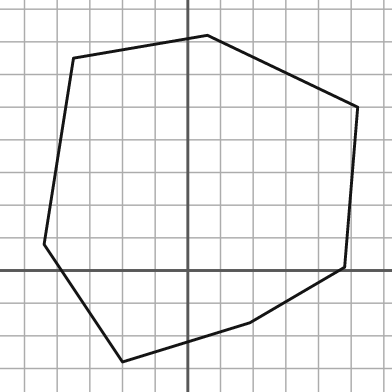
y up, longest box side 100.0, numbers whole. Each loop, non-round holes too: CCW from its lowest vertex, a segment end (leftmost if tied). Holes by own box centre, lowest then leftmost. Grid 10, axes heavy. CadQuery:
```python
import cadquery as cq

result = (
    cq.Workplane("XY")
    .moveTo(-20.0, -28.0)
    .lineTo(19.0, -16.0)
    .lineTo(48.0, 1.0)
    .lineTo(52.0, 50.0)
    .lineTo(6.0, 72.0)
    .lineTo(-35.0, 65.0)
    .lineTo(-44.0, 8.0)
    .close()
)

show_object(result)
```